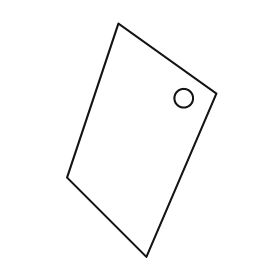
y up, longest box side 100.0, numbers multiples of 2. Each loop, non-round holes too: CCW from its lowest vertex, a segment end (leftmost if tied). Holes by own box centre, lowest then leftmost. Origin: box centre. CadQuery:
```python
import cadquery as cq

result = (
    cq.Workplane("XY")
    .moveTo(2.0, -50.0)
    .lineTo(32.0, 20.0)
    .lineTo(-10.0, 50.0)
    .lineTo(-32.0, -16.0)
    .close()
    .moveTo(18.0, 18.0)
    .circle(4.0)
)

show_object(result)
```